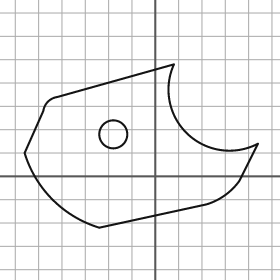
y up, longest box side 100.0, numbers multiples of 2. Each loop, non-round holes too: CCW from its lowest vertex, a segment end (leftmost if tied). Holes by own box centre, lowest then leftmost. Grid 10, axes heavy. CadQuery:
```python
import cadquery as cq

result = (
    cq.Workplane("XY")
    .moveTo(-24.0, -22.0)
    .lineTo(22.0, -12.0)
    .threePointArc((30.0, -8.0), (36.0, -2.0))
    .lineTo(44.0, 14.0)
    .threePointArc((14.0, 18.0), (8.0, 48.0))
    .lineTo(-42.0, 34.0)
    .threePointArc((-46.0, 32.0), (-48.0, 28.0))
    .lineTo(-56.0, 10.0)
    .threePointArc((-44.0, -10.0), (-24.0, -22.0))
    .close()
    .moveTo(-18.0, 18.0)
    .circle(6.0)
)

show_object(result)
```